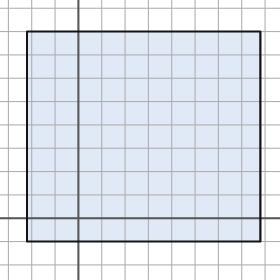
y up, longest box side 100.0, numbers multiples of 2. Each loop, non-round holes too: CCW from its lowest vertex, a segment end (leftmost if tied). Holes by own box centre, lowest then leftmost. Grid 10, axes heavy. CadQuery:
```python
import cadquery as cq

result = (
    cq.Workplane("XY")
    .moveTo(-22.0, -10.0)
    .lineTo(78.0, -10.0)
    .lineTo(78.0, 80.0)
    .lineTo(-22.0, 80.0)
    .close()
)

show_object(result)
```